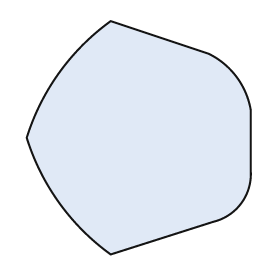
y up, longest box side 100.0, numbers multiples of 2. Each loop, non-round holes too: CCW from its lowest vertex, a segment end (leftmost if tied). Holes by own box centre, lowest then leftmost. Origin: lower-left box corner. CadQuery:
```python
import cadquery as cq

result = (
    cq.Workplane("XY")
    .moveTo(36.0, 0.0)
    .lineTo(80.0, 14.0)
    .threePointArc((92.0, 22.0), (96.0, 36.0))
    .lineTo(96.0, 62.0)
    .threePointArc((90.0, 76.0), (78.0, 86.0))
    .lineTo(36.0, 100.0)
    .threePointArc((14.0, 78.0), (0.0, 50.0))
    .threePointArc((14.0, 22.0), (36.0, 0.0))
    .close()
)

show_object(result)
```